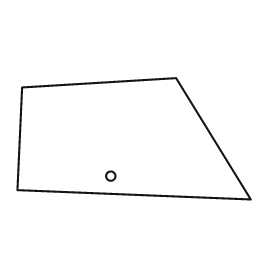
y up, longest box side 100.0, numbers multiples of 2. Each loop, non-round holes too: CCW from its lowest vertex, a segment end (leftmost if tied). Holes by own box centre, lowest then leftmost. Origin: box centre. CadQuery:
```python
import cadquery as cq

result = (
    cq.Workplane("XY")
    .moveTo(50.0, -26.0)
    .lineTo(18.0, 26.0)
    .lineTo(-48.0, 22.0)
    .lineTo(-50.0, -22.0)
    .close()
    .moveTo(-10.0, -16.0)
    .circle(2.0)
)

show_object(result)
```